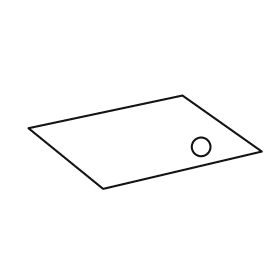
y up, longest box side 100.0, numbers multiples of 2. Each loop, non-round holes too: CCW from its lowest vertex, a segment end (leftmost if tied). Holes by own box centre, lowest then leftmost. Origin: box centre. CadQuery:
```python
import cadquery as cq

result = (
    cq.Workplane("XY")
    .moveTo(-18.0, -20.0)
    .lineTo(50.0, -4.0)
    .lineTo(16.0, 20.0)
    .lineTo(-50.0, 6.0)
    .close()
    .moveTo(24.0, -2.0)
    .circle(4.0)
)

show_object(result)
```